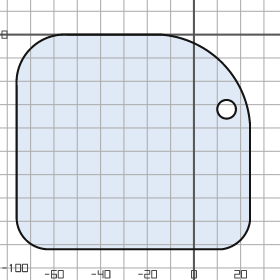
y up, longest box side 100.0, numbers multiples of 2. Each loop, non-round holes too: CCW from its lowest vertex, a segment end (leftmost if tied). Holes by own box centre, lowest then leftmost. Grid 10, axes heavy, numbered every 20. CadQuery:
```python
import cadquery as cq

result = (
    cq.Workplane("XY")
    .moveTo(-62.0, -92.0)
    .lineTo(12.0, -92.0)
    .threePointArc((20.0, -88.0), (24.0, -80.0))
    .lineTo(24.0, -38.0)
    .threePointArc((12.0, -12.0), (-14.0, 0.0))
    .lineTo(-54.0, 0.0)
    .threePointArc((-70.0, -6.0), (-76.0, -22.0))
    .lineTo(-76.0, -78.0)
    .threePointArc((-72.0, -88.0), (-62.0, -92.0))
    .close()
    .moveTo(14.0, -32.0)
    .circle(4.0)
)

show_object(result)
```